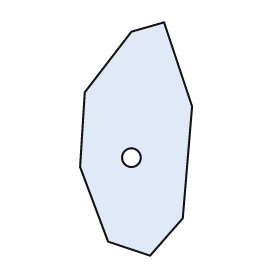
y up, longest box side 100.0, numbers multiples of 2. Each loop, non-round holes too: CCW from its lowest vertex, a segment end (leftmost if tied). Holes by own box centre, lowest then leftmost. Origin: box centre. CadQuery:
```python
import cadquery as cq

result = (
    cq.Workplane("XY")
    .moveTo(6.0, -50.0)
    .lineTo(20.0, -34.0)
    .lineTo(24.0, 14.0)
    .lineTo(12.0, 50.0)
    .lineTo(-2.0, 46.0)
    .lineTo(-22.0, 20.0)
    .lineTo(-24.0, -12.0)
    .lineTo(-12.0, -44.0)
    .close()
    .moveTo(-2.0, -8.0)
    .circle(4.0)
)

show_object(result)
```